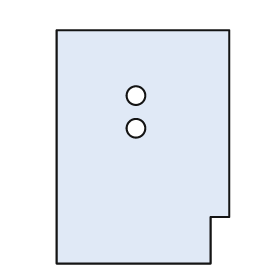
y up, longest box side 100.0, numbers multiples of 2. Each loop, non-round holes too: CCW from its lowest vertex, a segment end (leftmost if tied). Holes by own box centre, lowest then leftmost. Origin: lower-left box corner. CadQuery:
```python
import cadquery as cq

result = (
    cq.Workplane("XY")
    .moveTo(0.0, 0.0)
    .lineTo(66.0, 0.0)
    .lineTo(66.0, 20.0)
    .lineTo(74.0, 20.0)
    .lineTo(74.0, 100.0)
    .lineTo(0.0, 100.0)
    .close()
    .moveTo(34.0, 58.0)
    .circle(4.0)
    .moveTo(34.0, 72.0)
    .circle(4.0)
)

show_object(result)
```